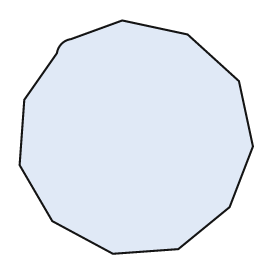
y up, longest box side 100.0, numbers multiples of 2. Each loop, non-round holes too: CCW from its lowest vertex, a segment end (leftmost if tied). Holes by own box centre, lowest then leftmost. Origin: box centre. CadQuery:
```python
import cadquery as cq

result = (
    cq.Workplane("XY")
    .moveTo(-10.0, -50.0)
    .lineTo(18.0, -48.0)
    .lineTo(40.0, -30.0)
    .lineTo(50.0, -4.0)
    .lineTo(44.0, 24.0)
    .lineTo(22.0, 44.0)
    .lineTo(-6.0, 50.0)
    .lineTo(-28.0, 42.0)
    .threePointArc((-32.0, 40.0), (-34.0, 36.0))
    .lineTo(-48.0, 16.0)
    .lineTo(-50.0, -12.0)
    .lineTo(-36.0, -36.0)
    .close()
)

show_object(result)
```